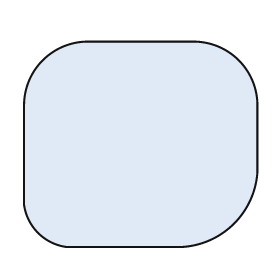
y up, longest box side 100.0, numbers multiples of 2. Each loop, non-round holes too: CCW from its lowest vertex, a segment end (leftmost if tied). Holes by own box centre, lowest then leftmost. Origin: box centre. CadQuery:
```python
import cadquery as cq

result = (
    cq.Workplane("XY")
    .moveTo(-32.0, -44.0)
    .lineTo(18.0, -44.0)
    .threePointArc((40.0, -34.0), (50.0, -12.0))
    .lineTo(50.0, 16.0)
    .threePointArc((42.0, 36.0), (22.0, 44.0))
    .lineTo(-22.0, 44.0)
    .threePointArc((-42.0, 36.0), (-50.0, 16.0))
    .lineTo(-50.0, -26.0)
    .threePointArc((-44.0, -38.0), (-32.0, -44.0))
    .close()
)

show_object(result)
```